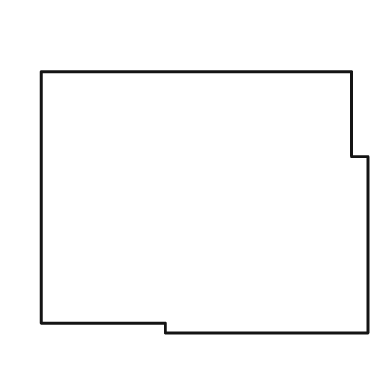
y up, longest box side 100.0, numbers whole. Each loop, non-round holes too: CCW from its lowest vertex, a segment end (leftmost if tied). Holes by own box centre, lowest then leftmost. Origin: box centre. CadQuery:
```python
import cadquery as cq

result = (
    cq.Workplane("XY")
    .moveTo(-12.0, -40.0)
    .lineTo(50.0, -40.0)
    .lineTo(50.0, 14.0)
    .lineTo(45.0, 14.0)
    .lineTo(45.0, 40.0)
    .lineTo(-50.0, 40.0)
    .lineTo(-50.0, -37.0)
    .lineTo(-12.0, -37.0)
    .close()
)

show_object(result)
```